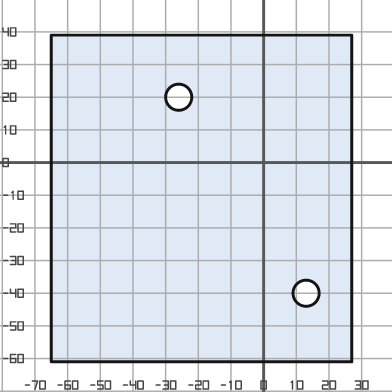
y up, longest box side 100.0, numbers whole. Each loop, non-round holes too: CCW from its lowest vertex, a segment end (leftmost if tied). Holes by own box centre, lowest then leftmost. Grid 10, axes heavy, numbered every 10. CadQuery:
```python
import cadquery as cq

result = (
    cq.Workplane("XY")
    .moveTo(-65.0, -61.0)
    .lineTo(27.0, -61.0)
    .lineTo(27.0, 39.0)
    .lineTo(-65.0, 39.0)
    .close()
    .moveTo(13.0, -40.0)
    .circle(4.0)
    .moveTo(-26.0, 20.0)
    .circle(4.0)
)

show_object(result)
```